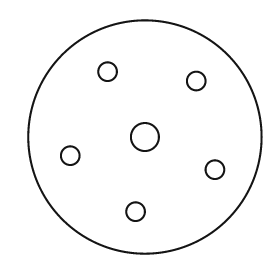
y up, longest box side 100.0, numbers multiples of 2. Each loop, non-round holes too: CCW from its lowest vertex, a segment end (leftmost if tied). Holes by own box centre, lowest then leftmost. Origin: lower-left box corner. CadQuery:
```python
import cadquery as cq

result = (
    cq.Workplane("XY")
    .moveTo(50.0, 50.0)
    .circle(50.0)
    .moveTo(46.0, 18.0)
    .circle(4.0)
    .moveTo(80.0, 36.0)
    .circle(4.0)
    .moveTo(18.0, 42.0)
    .circle(4.0)
    .moveTo(50.0, 50.0)
    .circle(6.0)
    .moveTo(72.0, 74.0)
    .circle(4.0)
    .moveTo(34.0, 78.0)
    .circle(4.0)
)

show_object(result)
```